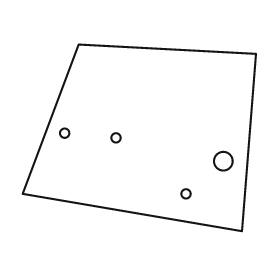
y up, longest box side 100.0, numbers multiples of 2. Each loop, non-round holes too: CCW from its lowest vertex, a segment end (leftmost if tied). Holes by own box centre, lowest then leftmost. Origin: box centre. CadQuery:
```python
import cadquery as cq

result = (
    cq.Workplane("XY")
    .moveTo(44.0, -40.0)
    .lineTo(50.0, 36.0)
    .lineTo(-26.0, 40.0)
    .lineTo(-50.0, -24.0)
    .close()
    .moveTo(20.0, -24.0)
    .circle(2.0)
    .moveTo(36.0, -10.0)
    .circle(4.0)
    .moveTo(-10.0, 0.0)
    .circle(2.0)
    .moveTo(-32.0, 2.0)
    .circle(2.0)
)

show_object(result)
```